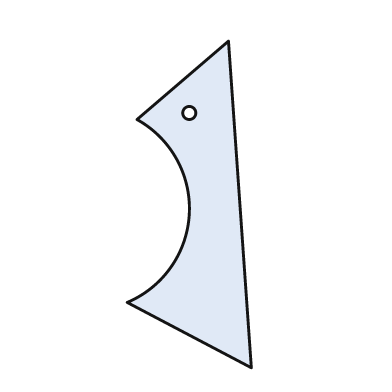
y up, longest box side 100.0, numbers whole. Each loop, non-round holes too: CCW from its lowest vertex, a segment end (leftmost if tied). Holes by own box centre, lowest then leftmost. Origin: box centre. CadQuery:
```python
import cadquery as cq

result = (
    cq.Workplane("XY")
    .moveTo(19.0, -50.0)
    .lineTo(12.0, 50.0)
    .lineTo(-16.0, 26.0)
    .threePointArc((0.0, -3.0), (-19.0, -30.0))
    .close()
    .moveTo(0.0, 28.0)
    .circle(2.0)
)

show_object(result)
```